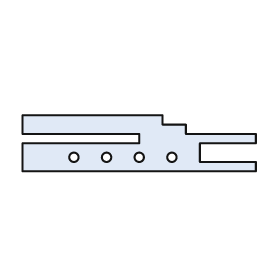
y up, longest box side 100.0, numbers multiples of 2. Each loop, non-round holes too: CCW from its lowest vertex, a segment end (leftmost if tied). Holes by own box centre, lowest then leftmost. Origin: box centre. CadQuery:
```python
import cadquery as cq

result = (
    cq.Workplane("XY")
    .moveTo(-50.0, -12.0)
    .lineTo(50.0, -12.0)
    .lineTo(50.0, -8.0)
    .lineTo(26.0, -8.0)
    .lineTo(26.0, 0.0)
    .lineTo(50.0, 0.0)
    .lineTo(50.0, 4.0)
    .lineTo(20.0, 4.0)
    .lineTo(20.0, 8.0)
    .lineTo(10.0, 8.0)
    .lineTo(10.0, 12.0)
    .lineTo(-50.0, 12.0)
    .lineTo(-50.0, 4.0)
    .lineTo(0.0, 4.0)
    .lineTo(0.0, 0.0)
    .lineTo(-50.0, 0.0)
    .close()
    .moveTo(-28.0, -6.0)
    .circle(2.0)
    .moveTo(-14.0, -6.0)
    .circle(2.0)
    .moveTo(0.0, -6.0)
    .circle(2.0)
    .moveTo(14.0, -6.0)
    .circle(2.0)
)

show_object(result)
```